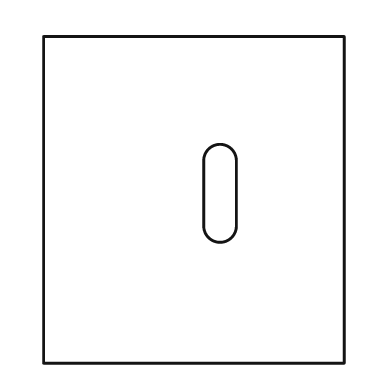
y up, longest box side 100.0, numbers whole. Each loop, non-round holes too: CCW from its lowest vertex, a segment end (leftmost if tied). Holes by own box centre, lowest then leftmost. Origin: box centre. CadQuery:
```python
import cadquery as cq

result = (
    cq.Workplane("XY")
    .moveTo(-46.0, -50.0)
    .lineTo(46.0, -50.0)
    .lineTo(46.0, 50.0)
    .lineTo(-46.0, 50.0)
    .close()
    .moveTo(3.0, -8.0)
    .threePointArc((8.0, -13.0), (13.0, -8.0))
    .lineTo(13.0, 12.0)
    .threePointArc((8.0, 17.0), (3.0, 12.0))
    .close()
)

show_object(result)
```